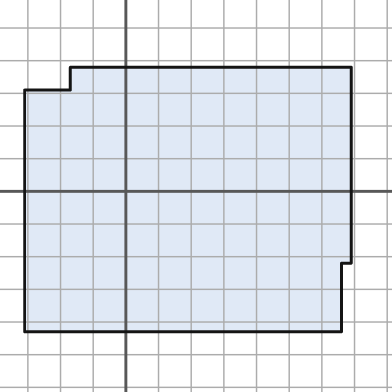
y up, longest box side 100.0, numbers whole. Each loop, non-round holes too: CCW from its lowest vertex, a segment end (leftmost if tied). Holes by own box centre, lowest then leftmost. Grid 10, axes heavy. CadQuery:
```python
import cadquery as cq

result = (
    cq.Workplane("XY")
    .moveTo(-31.0, -43.0)
    .lineTo(66.0, -43.0)
    .lineTo(66.0, -22.0)
    .lineTo(69.0, -22.0)
    .lineTo(69.0, 38.0)
    .lineTo(-17.0, 38.0)
    .lineTo(-17.0, 31.0)
    .lineTo(-31.0, 31.0)
    .close()
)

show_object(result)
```